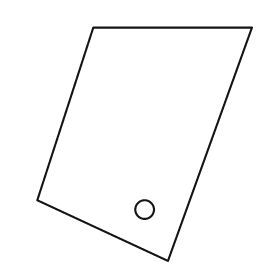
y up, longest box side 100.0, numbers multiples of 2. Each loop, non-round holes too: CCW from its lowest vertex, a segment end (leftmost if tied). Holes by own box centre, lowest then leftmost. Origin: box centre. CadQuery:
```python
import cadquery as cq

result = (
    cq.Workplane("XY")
    .moveTo(10.0, -50.0)
    .lineTo(46.0, 50.0)
    .lineTo(-22.0, 50.0)
    .lineTo(-46.0, -24.0)
    .close()
    .moveTo(0.0, -28.0)
    .circle(4.0)
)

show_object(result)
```